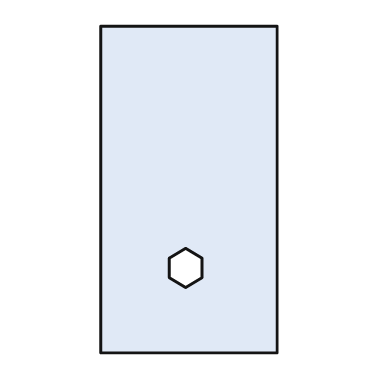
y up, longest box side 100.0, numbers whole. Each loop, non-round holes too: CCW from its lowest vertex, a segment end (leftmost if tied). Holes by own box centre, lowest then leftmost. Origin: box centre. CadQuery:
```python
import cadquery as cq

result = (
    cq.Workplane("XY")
    .moveTo(-27.0, -50.0)
    .lineTo(27.0, -50.0)
    .lineTo(27.0, 50.0)
    .lineTo(-27.0, 50.0)
    .close()
    .moveTo(-1.0, -30.0)
    .lineTo(4.0, -27.0)
    .lineTo(4.0, -21.0)
    .lineTo(-1.0, -18.0)
    .lineTo(-6.0, -21.0)
    .lineTo(-6.0, -27.0)
    .close()
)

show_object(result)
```